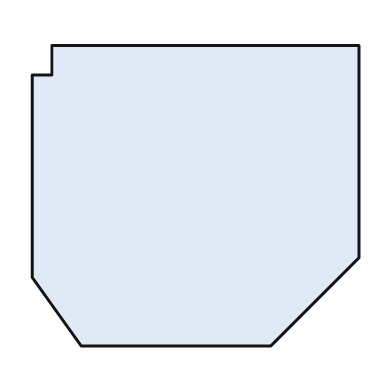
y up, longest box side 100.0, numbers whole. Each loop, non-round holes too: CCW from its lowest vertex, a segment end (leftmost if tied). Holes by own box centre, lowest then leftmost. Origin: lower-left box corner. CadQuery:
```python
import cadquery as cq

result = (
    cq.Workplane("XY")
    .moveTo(15.0, 0.0)
    .lineTo(73.0, 0.0)
    .lineTo(100.0, 27.0)
    .lineTo(100.0, 92.0)
    .lineTo(6.0, 92.0)
    .lineTo(6.0, 83.0)
    .lineTo(0.0, 83.0)
    .lineTo(0.0, 21.0)
    .close()
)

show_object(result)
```